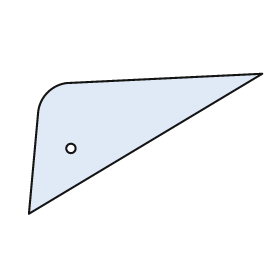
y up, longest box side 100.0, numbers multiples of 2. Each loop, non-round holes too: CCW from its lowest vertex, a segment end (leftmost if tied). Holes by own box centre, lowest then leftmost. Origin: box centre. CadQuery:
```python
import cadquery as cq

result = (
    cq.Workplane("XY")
    .moveTo(-50.0, -30.0)
    .lineTo(50.0, 30.0)
    .lineTo(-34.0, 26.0)
    .threePointArc((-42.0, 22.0), (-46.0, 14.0))
    .close()
    .moveTo(-32.0, -2.0)
    .circle(2.0)
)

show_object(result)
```